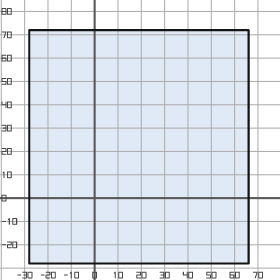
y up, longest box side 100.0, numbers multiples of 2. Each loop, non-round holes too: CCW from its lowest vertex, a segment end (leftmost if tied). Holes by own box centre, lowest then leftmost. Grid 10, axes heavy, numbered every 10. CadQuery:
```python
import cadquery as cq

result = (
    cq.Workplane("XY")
    .moveTo(-28.0, -28.0)
    .lineTo(66.0, -28.0)
    .lineTo(66.0, 72.0)
    .lineTo(-28.0, 72.0)
    .close()
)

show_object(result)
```